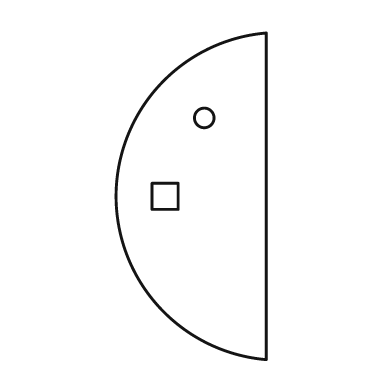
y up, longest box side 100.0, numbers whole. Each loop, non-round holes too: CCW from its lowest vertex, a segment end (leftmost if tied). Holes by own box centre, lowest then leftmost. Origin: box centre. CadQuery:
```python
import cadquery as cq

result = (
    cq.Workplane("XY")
    .moveTo(23.0, -50.0)
    .lineTo(23.0, 50.0)
    .threePointArc((-23.0, 0.0), (23.0, -50.0))
    .close()
    .moveTo(-12.0, -4.0)
    .lineTo(-4.0, -4.0)
    .lineTo(-4.0, 4.0)
    .lineTo(-12.0, 4.0)
    .close()
    .moveTo(4.0, 24.0)
    .circle(3.0)
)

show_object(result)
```